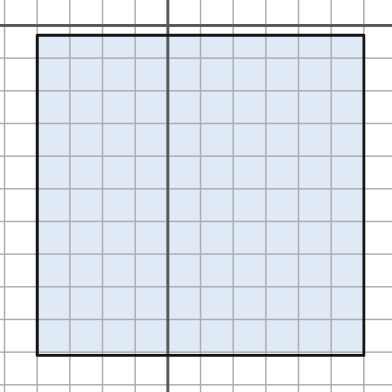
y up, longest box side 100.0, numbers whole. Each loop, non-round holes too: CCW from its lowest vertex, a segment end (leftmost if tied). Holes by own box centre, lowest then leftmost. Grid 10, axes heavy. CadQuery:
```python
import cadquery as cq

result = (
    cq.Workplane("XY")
    .moveTo(-40.0, -101.0)
    .lineTo(60.0, -101.0)
    .lineTo(60.0, -3.0)
    .lineTo(-40.0, -3.0)
    .close()
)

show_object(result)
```